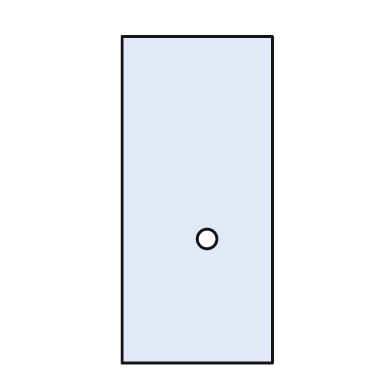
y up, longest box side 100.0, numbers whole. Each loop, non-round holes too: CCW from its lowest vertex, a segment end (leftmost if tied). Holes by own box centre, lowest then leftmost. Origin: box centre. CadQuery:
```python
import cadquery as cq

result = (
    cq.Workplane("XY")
    .moveTo(-23.0, -50.0)
    .lineTo(23.0, -50.0)
    .lineTo(23.0, 50.0)
    .lineTo(-23.0, 50.0)
    .close()
    .moveTo(3.0, -12.0)
    .circle(3.0)
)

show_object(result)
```